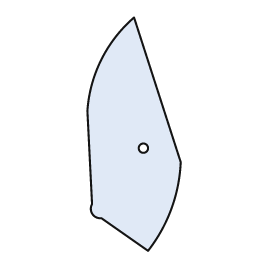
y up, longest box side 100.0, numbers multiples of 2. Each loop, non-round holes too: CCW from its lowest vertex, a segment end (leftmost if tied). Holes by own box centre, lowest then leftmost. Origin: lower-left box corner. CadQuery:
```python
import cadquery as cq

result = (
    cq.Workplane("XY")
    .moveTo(26.0, 0.0)
    .threePointArc((36.0, 18.0), (40.0, 38.0))
    .lineTo(20.0, 100.0)
    .threePointArc((6.0, 82.0), (0.0, 60.0))
    .lineTo(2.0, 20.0)
    .threePointArc((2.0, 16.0), (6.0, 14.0))
    .close()
    .moveTo(24.0, 44.0)
    .circle(2.0)
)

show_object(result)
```